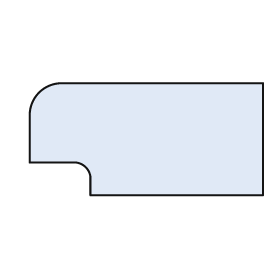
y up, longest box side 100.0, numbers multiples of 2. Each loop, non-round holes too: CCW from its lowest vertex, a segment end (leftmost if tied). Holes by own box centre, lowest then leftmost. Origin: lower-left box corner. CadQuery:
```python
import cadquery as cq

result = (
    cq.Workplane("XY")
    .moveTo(26.0, 0.0)
    .lineTo(100.0, 0.0)
    .lineTo(100.0, 48.0)
    .lineTo(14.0, 48.0)
    .threePointArc((4.0, 44.0), (0.0, 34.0))
    .lineTo(0.0, 14.0)
    .lineTo(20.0, 14.0)
    .threePointArc((24.0, 12.0), (26.0, 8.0))
    .close()
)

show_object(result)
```